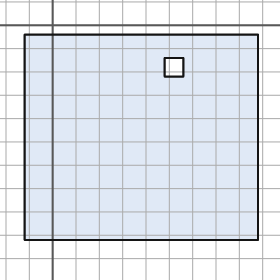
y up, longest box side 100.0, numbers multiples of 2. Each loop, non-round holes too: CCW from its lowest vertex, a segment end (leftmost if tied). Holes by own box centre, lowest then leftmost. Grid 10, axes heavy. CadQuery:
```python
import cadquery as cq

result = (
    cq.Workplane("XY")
    .moveTo(-12.0, -92.0)
    .lineTo(88.0, -92.0)
    .lineTo(88.0, -4.0)
    .lineTo(-12.0, -4.0)
    .close()
    .moveTo(48.0, -22.0)
    .lineTo(56.0, -22.0)
    .lineTo(56.0, -14.0)
    .lineTo(48.0, -14.0)
    .close()
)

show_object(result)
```